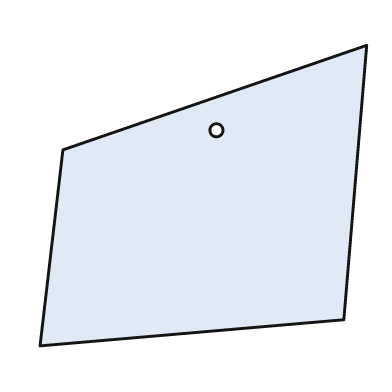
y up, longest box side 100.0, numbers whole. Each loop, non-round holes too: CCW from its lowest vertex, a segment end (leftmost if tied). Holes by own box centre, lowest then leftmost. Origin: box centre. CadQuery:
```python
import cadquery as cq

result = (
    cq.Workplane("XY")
    .moveTo(-50.0, -46.0)
    .lineTo(43.0, -38.0)
    .lineTo(50.0, 46.0)
    .lineTo(-43.0, 14.0)
    .close()
    .moveTo(4.0, 20.0)
    .circle(2.0)
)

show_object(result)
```